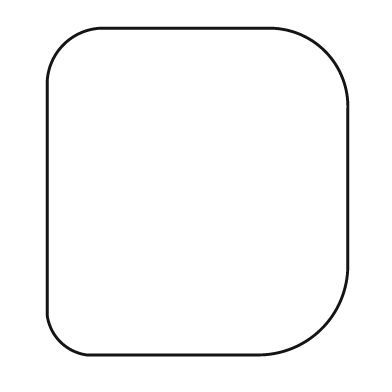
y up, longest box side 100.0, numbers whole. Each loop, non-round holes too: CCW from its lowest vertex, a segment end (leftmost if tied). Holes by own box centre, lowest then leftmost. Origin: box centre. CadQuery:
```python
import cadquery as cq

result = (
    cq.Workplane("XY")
    .moveTo(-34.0, -50.0)
    .lineTo(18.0, -50.0)
    .threePointArc((38.0, -42.0), (46.0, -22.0))
    .lineTo(46.0, 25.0)
    .threePointArc((39.0, 43.0), (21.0, 50.0))
    .lineTo(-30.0, 50.0)
    .threePointArc((-41.0, 45.0), (-46.0, 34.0))
    .lineTo(-46.0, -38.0)
    .threePointArc((-42.0, -46.0), (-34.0, -50.0))
    .close()
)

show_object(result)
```